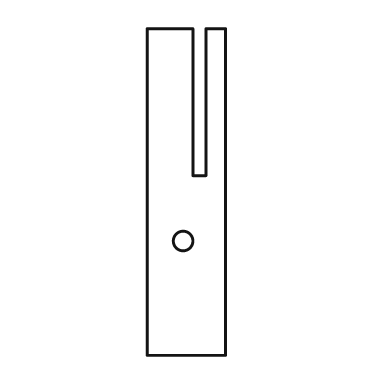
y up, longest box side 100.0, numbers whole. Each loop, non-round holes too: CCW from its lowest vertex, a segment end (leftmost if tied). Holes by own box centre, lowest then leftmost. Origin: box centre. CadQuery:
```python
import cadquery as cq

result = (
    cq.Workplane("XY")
    .moveTo(-12.0, -50.0)
    .lineTo(12.0, -50.0)
    .lineTo(12.0, 50.0)
    .lineTo(6.0, 50.0)
    .lineTo(6.0, 5.0)
    .lineTo(2.0, 5.0)
    .lineTo(2.0, 50.0)
    .lineTo(-12.0, 50.0)
    .close()
    .moveTo(-1.0, -15.0)
    .circle(3.0)
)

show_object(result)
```